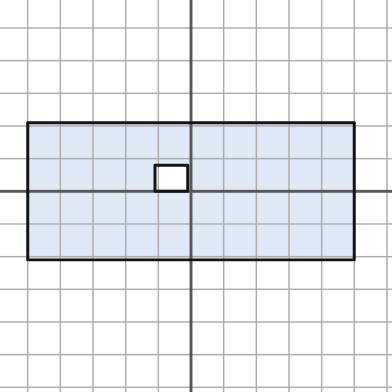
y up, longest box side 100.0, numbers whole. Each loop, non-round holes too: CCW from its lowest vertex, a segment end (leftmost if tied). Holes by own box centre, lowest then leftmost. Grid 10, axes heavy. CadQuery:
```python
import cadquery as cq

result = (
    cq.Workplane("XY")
    .moveTo(-50.0, -21.0)
    .lineTo(50.0, -21.0)
    .lineTo(50.0, 21.0)
    .lineTo(-50.0, 21.0)
    .close()
    .moveTo(-11.0, 0.0)
    .lineTo(-1.0, 0.0)
    .lineTo(-1.0, 8.0)
    .lineTo(-11.0, 8.0)
    .close()
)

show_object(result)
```